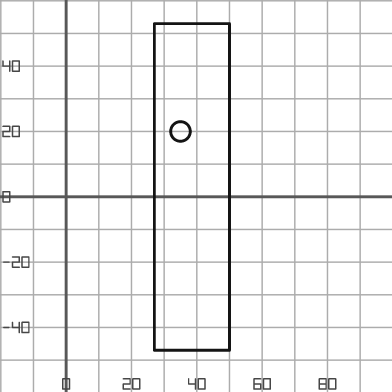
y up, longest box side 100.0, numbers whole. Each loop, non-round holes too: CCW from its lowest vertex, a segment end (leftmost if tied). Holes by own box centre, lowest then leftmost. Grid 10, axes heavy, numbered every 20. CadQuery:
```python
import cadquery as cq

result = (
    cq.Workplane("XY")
    .moveTo(27.0, -47.0)
    .lineTo(50.0, -47.0)
    .lineTo(50.0, 53.0)
    .lineTo(27.0, 53.0)
    .close()
    .moveTo(35.0, 20.0)
    .circle(3.0)
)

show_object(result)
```